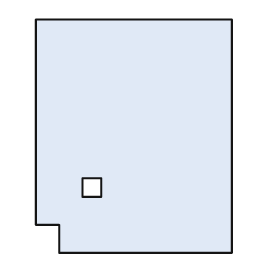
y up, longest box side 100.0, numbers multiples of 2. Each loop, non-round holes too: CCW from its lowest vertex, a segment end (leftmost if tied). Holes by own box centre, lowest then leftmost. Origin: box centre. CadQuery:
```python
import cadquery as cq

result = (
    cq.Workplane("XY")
    .moveTo(-32.0, -50.0)
    .lineTo(42.0, -50.0)
    .lineTo(42.0, 50.0)
    .lineTo(-42.0, 50.0)
    .lineTo(-42.0, -38.0)
    .lineTo(-32.0, -38.0)
    .close()
    .moveTo(-22.0, -26.0)
    .lineTo(-14.0, -26.0)
    .lineTo(-14.0, -18.0)
    .lineTo(-22.0, -18.0)
    .close()
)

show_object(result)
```